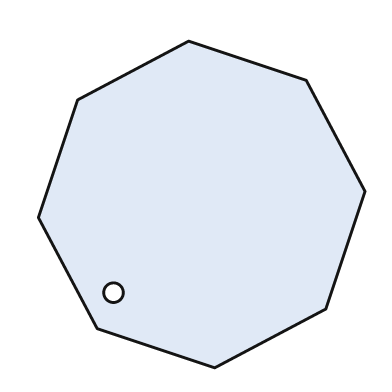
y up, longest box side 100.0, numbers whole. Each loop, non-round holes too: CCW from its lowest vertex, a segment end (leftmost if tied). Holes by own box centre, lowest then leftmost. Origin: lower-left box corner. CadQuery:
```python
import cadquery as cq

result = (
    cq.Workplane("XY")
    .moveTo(54.0, 0.0)
    .lineTo(88.0, 18.0)
    .lineTo(100.0, 54.0)
    .lineTo(82.0, 88.0)
    .lineTo(46.0, 100.0)
    .lineTo(12.0, 82.0)
    .lineTo(0.0, 46.0)
    .lineTo(18.0, 12.0)
    .close()
    .moveTo(23.0, 23.0)
    .circle(3.0)
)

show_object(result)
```